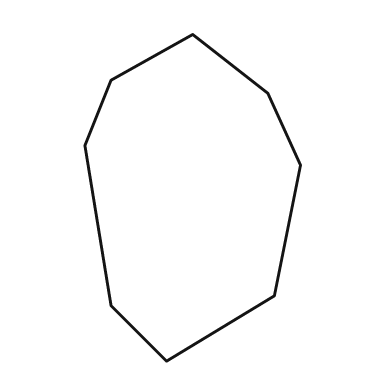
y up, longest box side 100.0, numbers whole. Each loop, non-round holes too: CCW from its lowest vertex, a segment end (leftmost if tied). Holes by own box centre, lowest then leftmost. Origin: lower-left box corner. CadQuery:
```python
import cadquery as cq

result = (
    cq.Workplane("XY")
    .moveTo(25.0, 0.0)
    .lineTo(58.0, 20.0)
    .lineTo(66.0, 60.0)
    .lineTo(56.0, 82.0)
    .lineTo(33.0, 100.0)
    .lineTo(8.0, 86.0)
    .lineTo(0.0, 66.0)
    .lineTo(8.0, 17.0)
    .close()
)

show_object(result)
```